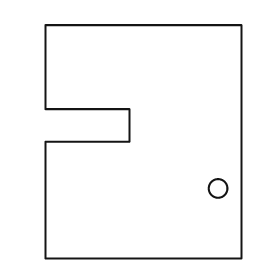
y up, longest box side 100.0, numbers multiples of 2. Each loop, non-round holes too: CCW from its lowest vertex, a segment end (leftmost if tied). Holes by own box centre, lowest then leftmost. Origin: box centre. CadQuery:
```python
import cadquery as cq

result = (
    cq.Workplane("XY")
    .moveTo(-42.0, -50.0)
    .lineTo(42.0, -50.0)
    .lineTo(42.0, 50.0)
    .lineTo(-42.0, 50.0)
    .lineTo(-42.0, 14.0)
    .lineTo(-6.0, 14.0)
    .lineTo(-6.0, 0.0)
    .lineTo(-42.0, 0.0)
    .close()
    .moveTo(32.0, -20.0)
    .circle(4.0)
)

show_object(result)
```